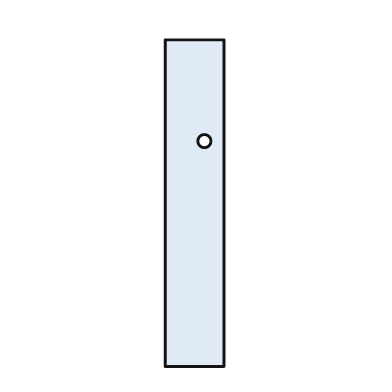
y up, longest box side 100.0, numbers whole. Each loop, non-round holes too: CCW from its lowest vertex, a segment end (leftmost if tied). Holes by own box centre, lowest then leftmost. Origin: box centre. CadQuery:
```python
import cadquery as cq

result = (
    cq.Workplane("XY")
    .moveTo(-9.0, -50.0)
    .lineTo(9.0, -50.0)
    .lineTo(9.0, 50.0)
    .lineTo(-9.0, 50.0)
    .close()
    .moveTo(3.0, 19.0)
    .circle(2.0)
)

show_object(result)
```